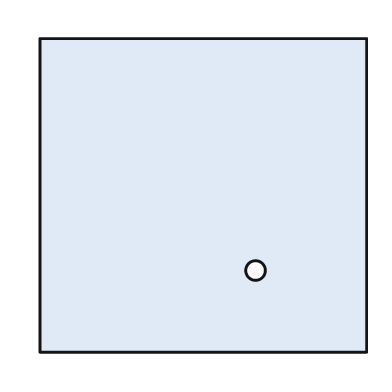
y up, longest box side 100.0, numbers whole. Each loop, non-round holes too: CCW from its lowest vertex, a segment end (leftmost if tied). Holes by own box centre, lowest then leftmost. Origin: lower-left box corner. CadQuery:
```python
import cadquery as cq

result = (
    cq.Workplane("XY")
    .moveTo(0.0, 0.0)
    .lineTo(100.0, 0.0)
    .lineTo(100.0, 96.0)
    .lineTo(0.0, 96.0)
    .close()
    .moveTo(66.0, 25.0)
    .circle(3.0)
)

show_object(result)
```